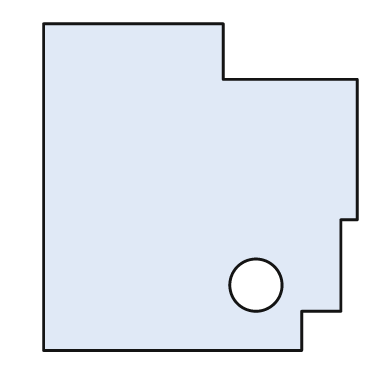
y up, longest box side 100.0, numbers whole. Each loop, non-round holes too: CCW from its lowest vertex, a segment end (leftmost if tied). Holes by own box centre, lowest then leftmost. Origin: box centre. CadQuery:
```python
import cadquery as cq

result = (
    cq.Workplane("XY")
    .moveTo(-48.0, -50.0)
    .lineTo(31.0, -50.0)
    .lineTo(31.0, -38.0)
    .lineTo(43.0, -38.0)
    .lineTo(43.0, -10.0)
    .lineTo(48.0, -10.0)
    .lineTo(48.0, 33.0)
    .lineTo(7.0, 33.0)
    .lineTo(7.0, 50.0)
    .lineTo(-48.0, 50.0)
    .close()
    .moveTo(17.0, -30.0)
    .circle(8.0)
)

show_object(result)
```